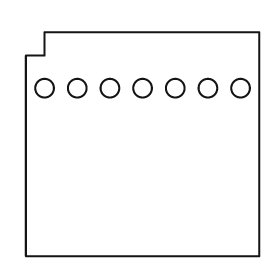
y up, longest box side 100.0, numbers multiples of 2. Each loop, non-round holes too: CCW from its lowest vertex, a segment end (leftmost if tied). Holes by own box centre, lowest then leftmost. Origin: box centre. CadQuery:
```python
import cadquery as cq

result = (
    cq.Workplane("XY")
    .moveTo(-50.0, -48.0)
    .lineTo(50.0, -48.0)
    .lineTo(50.0, 48.0)
    .lineTo(-42.0, 48.0)
    .lineTo(-42.0, 38.0)
    .lineTo(-50.0, 38.0)
    .close()
    .moveTo(-42.0, 24.0)
    .circle(4.0)
    .moveTo(-28.0, 24.0)
    .circle(4.0)
    .moveTo(-14.0, 24.0)
    .circle(4.0)
    .moveTo(0.0, 24.0)
    .circle(4.0)
    .moveTo(14.0, 24.0)
    .circle(4.0)
    .moveTo(28.0, 24.0)
    .circle(4.0)
    .moveTo(42.0, 24.0)
    .circle(4.0)
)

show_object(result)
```